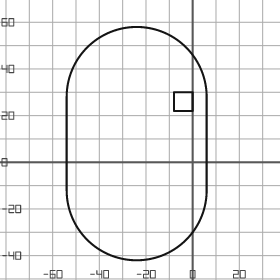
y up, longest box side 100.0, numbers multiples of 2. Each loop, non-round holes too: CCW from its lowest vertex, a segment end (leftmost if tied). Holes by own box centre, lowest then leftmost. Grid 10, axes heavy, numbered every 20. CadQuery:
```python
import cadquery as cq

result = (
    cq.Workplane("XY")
    .moveTo(-54.0, -12.0)
    .threePointArc((-24.0, -42.0), (6.0, -12.0))
    .lineTo(6.0, 28.0)
    .threePointArc((-24.0, 58.0), (-54.0, 28.0))
    .close()
    .moveTo(-8.0, 22.0)
    .lineTo(0.0, 22.0)
    .lineTo(0.0, 30.0)
    .lineTo(-8.0, 30.0)
    .close()
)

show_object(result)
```